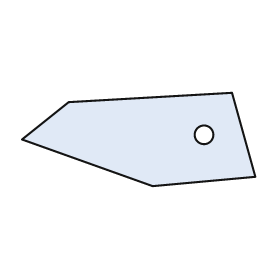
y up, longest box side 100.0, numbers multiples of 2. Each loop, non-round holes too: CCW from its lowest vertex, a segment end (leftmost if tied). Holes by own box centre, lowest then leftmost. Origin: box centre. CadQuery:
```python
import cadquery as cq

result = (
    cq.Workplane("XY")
    .moveTo(6.0, -20.0)
    .lineTo(50.0, -16.0)
    .lineTo(40.0, 20.0)
    .lineTo(-30.0, 16.0)
    .lineTo(-50.0, 0.0)
    .close()
    .moveTo(28.0, 2.0)
    .circle(4.0)
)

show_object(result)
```